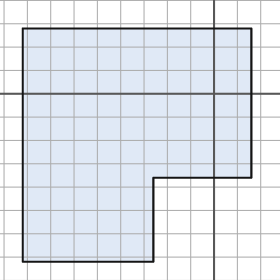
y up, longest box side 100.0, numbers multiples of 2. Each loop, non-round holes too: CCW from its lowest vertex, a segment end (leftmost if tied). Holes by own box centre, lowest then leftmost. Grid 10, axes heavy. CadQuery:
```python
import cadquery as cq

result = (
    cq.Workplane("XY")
    .moveTo(-82.0, -72.0)
    .lineTo(-26.0, -72.0)
    .lineTo(-26.0, -36.0)
    .lineTo(16.0, -36.0)
    .lineTo(16.0, 28.0)
    .lineTo(-82.0, 28.0)
    .close()
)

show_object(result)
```